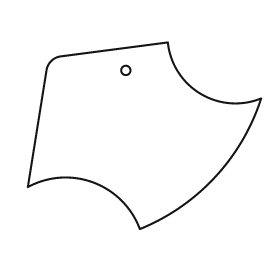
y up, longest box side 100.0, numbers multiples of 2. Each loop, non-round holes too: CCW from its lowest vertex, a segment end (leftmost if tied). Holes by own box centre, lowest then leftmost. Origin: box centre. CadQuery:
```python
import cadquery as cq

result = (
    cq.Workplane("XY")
    .moveTo(-2.0, -40.0)
    .threePointArc((30.0, -18.0), (50.0, 16.0))
    .threePointArc((24.0, 18.0), (10.0, 40.0))
    .lineTo(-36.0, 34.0)
    .threePointArc((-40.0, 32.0), (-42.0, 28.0))
    .lineTo(-50.0, -22.0)
    .threePointArc((-22.0, -20.0), (-2.0, -40.0))
    .close()
    .moveTo(-8.0, 28.0)
    .circle(2.0)
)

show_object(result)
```